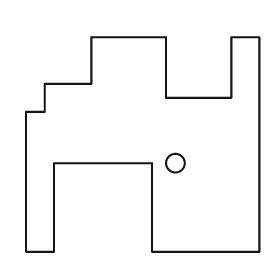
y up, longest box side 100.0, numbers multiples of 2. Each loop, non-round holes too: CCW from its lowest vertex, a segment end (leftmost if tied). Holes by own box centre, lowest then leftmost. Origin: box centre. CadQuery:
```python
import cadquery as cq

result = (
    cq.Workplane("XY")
    .moveTo(-50.0, -46.0)
    .lineTo(-38.0, -46.0)
    .lineTo(-38.0, -8.0)
    .lineTo(4.0, -8.0)
    .lineTo(4.0, -46.0)
    .lineTo(50.0, -46.0)
    .lineTo(50.0, 46.0)
    .lineTo(38.0, 46.0)
    .lineTo(38.0, 20.0)
    .lineTo(10.0, 20.0)
    .lineTo(10.0, 46.0)
    .lineTo(-22.0, 46.0)
    .lineTo(-22.0, 26.0)
    .lineTo(-42.0, 26.0)
    .lineTo(-42.0, 14.0)
    .lineTo(-50.0, 14.0)
    .close()
    .moveTo(14.0, -8.0)
    .circle(4.0)
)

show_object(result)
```